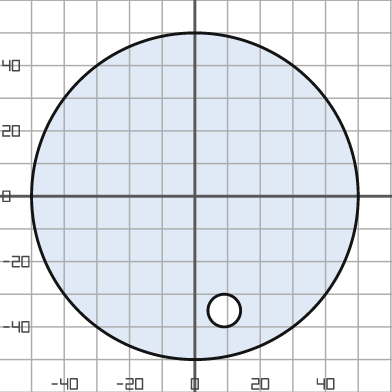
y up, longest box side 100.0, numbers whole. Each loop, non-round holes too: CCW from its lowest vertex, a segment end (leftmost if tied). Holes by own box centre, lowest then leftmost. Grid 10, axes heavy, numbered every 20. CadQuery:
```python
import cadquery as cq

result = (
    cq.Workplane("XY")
    .moveTo(0.0, 0.0)
    .circle(50.0)
    .moveTo(9.0, -35.0)
    .circle(5.0)
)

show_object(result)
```